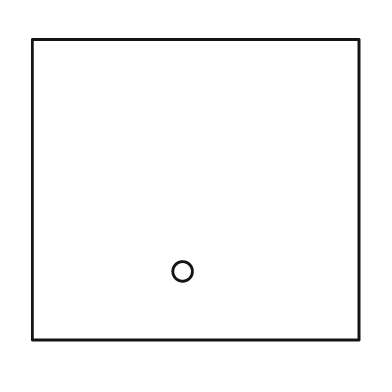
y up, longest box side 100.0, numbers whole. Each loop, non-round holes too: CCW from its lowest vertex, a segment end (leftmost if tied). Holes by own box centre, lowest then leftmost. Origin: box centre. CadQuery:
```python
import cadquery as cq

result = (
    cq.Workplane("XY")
    .moveTo(-50.0, -46.0)
    .lineTo(50.0, -46.0)
    .lineTo(50.0, 46.0)
    .lineTo(-50.0, 46.0)
    .close()
    .moveTo(-4.0, -25.0)
    .circle(3.0)
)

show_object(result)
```